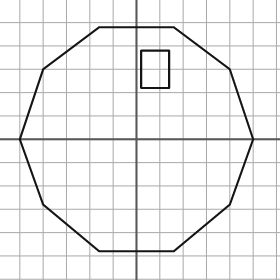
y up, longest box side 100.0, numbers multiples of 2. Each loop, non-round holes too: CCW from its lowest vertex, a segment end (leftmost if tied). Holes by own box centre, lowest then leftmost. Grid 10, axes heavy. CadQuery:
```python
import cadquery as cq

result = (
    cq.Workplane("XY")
    .moveTo(-16.0, -48.0)
    .lineTo(16.0, -48.0)
    .lineTo(40.0, -28.0)
    .lineTo(50.0, 0.0)
    .lineTo(40.0, 30.0)
    .lineTo(16.0, 48.0)
    .lineTo(-16.0, 48.0)
    .lineTo(-40.0, 30.0)
    .lineTo(-50.0, 0.0)
    .lineTo(-40.0, -28.0)
    .close()
    .moveTo(2.0, 22.0)
    .lineTo(14.0, 22.0)
    .lineTo(14.0, 38.0)
    .lineTo(2.0, 38.0)
    .close()
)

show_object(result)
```